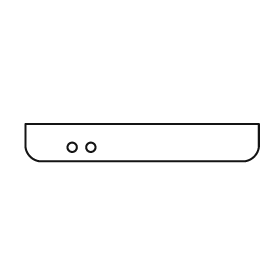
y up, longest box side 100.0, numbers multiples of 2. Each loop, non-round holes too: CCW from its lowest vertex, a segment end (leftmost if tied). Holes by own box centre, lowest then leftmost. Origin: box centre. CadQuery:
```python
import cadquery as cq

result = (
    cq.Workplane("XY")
    .moveTo(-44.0, -8.0)
    .lineTo(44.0, -8.0)
    .threePointArc((48.0, -6.0), (50.0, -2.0))
    .lineTo(50.0, 8.0)
    .lineTo(-50.0, 8.0)
    .lineTo(-50.0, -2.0)
    .threePointArc((-48.0, -6.0), (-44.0, -8.0))
    .close()
    .moveTo(-30.0, -2.0)
    .circle(2.0)
    .moveTo(-22.0, -2.0)
    .circle(2.0)
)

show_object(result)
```